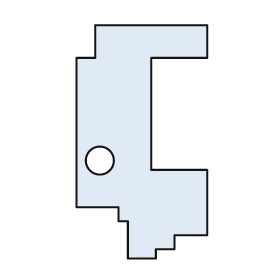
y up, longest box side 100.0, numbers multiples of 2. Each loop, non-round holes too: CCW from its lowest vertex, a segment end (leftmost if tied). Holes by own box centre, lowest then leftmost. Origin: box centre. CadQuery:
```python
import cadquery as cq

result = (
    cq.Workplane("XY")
    .moveTo(-6.0, -50.0)
    .lineTo(6.0, -50.0)
    .lineTo(6.0, -46.0)
    .lineTo(14.0, -46.0)
    .lineTo(14.0, -40.0)
    .lineTo(28.0, -40.0)
    .lineTo(28.0, -12.0)
    .lineTo(4.0, -12.0)
    .lineTo(4.0, 36.0)
    .lineTo(28.0, 36.0)
    .lineTo(28.0, 50.0)
    .lineTo(-20.0, 50.0)
    .lineTo(-20.0, 36.0)
    .lineTo(-28.0, 36.0)
    .lineTo(-28.0, -28.0)
    .lineTo(-10.0, -28.0)
    .lineTo(-10.0, -34.0)
    .lineTo(-6.0, -34.0)
    .close()
    .moveTo(-18.0, -8.0)
    .circle(6.0)
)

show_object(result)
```